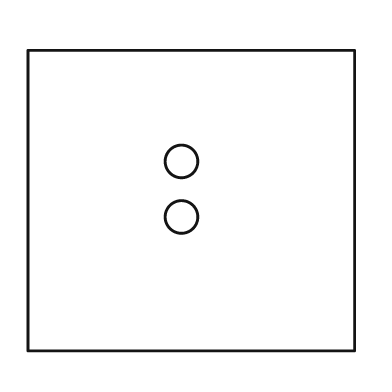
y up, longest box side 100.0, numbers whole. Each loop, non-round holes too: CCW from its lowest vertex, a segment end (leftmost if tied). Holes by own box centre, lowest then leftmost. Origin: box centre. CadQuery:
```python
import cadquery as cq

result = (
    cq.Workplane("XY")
    .moveTo(-50.0, -46.0)
    .lineTo(50.0, -46.0)
    .lineTo(50.0, 46.0)
    .lineTo(-50.0, 46.0)
    .close()
    .moveTo(-3.0, -5.0)
    .circle(5.0)
    .moveTo(-3.0, 12.0)
    .circle(5.0)
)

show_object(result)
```